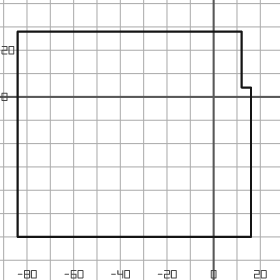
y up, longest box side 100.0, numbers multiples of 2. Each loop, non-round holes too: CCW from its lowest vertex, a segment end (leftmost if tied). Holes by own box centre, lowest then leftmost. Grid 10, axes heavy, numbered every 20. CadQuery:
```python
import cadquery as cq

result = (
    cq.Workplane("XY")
    .moveTo(-84.0, -60.0)
    .lineTo(16.0, -60.0)
    .lineTo(16.0, 4.0)
    .lineTo(12.0, 4.0)
    .lineTo(12.0, 28.0)
    .lineTo(-84.0, 28.0)
    .close()
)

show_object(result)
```